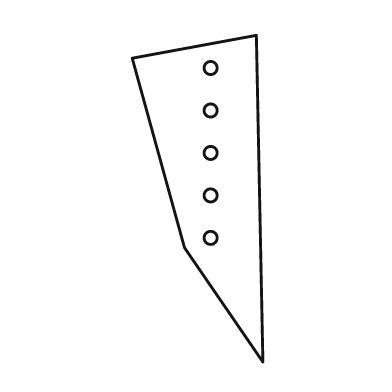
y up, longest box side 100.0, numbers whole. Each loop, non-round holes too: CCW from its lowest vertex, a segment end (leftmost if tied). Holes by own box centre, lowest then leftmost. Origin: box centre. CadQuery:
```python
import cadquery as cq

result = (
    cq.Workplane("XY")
    .moveTo(20.0, -50.0)
    .lineTo(18.0, 50.0)
    .lineTo(-20.0, 43.0)
    .lineTo(-4.0, -15.0)
    .close()
    .moveTo(4.0, -12.0)
    .circle(2.0)
    .moveTo(4.0, 1.0)
    .circle(2.0)
    .moveTo(4.0, 14.0)
    .circle(2.0)
    .moveTo(4.0, 27.0)
    .circle(2.0)
    .moveTo(4.0, 40.0)
    .circle(2.0)
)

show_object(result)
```